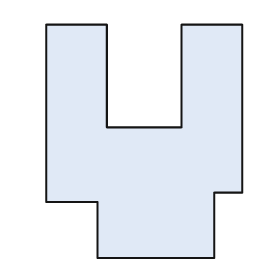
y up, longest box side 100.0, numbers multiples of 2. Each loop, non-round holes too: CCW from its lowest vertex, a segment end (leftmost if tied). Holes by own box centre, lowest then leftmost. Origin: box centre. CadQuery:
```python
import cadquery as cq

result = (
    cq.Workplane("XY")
    .moveTo(-20.0, -50.0)
    .lineTo(30.0, -50.0)
    .lineTo(30.0, -22.0)
    .lineTo(42.0, -22.0)
    .lineTo(42.0, 50.0)
    .lineTo(16.0, 50.0)
    .lineTo(16.0, 6.0)
    .lineTo(-16.0, 6.0)
    .lineTo(-16.0, 50.0)
    .lineTo(-42.0, 50.0)
    .lineTo(-42.0, -26.0)
    .lineTo(-20.0, -26.0)
    .close()
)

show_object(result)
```